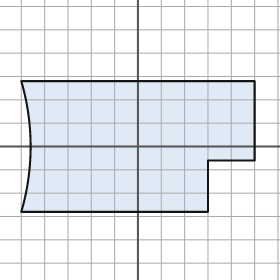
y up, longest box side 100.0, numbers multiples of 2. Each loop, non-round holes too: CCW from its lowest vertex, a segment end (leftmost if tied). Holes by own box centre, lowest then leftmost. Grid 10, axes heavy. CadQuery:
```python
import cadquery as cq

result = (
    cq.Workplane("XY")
    .moveTo(-50.0, -28.0)
    .lineTo(30.0, -28.0)
    .lineTo(30.0, -6.0)
    .lineTo(50.0, -6.0)
    .lineTo(50.0, 28.0)
    .lineTo(-50.0, 28.0)
    .threePointArc((-46.0, 0.0), (-50.0, -28.0))
    .close()
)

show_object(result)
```